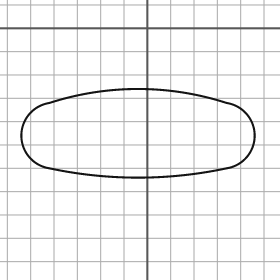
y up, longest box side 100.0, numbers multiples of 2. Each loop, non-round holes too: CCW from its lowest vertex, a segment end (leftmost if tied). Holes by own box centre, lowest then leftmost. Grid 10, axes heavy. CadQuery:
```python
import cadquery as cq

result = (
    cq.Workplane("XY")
    .moveTo(-42.0, -60.0)
    .threePointArc((-4.0, -64.0), (34.0, -60.0))
    .threePointArc((46.0, -46.0), (34.0, -32.0))
    .threePointArc((-4.0, -26.0), (-42.0, -32.0))
    .threePointArc((-54.0, -46.0), (-42.0, -60.0))
    .close()
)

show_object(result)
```